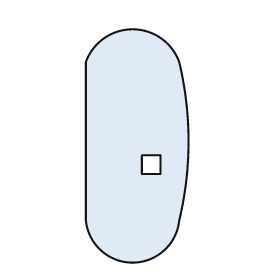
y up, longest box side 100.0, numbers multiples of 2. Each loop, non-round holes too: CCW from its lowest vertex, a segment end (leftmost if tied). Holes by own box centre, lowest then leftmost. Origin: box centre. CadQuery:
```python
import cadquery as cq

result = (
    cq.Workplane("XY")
    .moveTo(-22.0, -32.0)
    .threePointArc((-2.0, -50.0), (18.0, -32.0))
    .threePointArc((22.0, 2.0), (18.0, 36.0))
    .threePointArc((-2.0, 50.0), (-22.0, 36.0))
    .close()
    .moveTo(2.0, -12.0)
    .lineTo(10.0, -12.0)
    .lineTo(10.0, -4.0)
    .lineTo(2.0, -4.0)
    .close()
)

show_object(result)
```